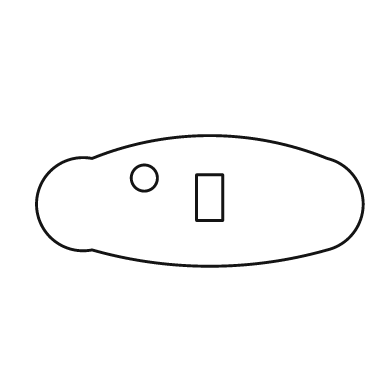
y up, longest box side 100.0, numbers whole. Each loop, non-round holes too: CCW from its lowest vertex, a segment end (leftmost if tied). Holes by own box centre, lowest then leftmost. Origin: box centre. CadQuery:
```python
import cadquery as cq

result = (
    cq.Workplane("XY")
    .moveTo(-33.0, -15.0)
    .threePointArc((3.0, -20.0), (39.0, -15.0))
    .threePointArc((50.0, -1.0), (39.0, 13.0))
    .threePointArc((3.0, 20.0), (-33.0, 13.0))
    .threePointArc((-50.0, -1.0), (-33.0, -15.0))
    .close()
    .moveTo(-1.0, -6.0)
    .lineTo(7.0, -6.0)
    .lineTo(7.0, 8.0)
    .lineTo(-1.0, 8.0)
    .close()
    .moveTo(-17.0, 7.0)
    .circle(4.0)
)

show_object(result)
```